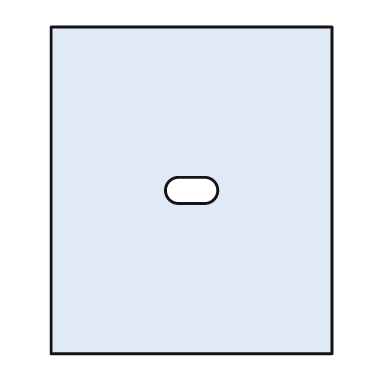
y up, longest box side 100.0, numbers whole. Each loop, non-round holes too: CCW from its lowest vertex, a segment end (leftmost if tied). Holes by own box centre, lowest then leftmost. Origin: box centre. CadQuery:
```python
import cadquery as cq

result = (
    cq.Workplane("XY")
    .moveTo(-43.0, -50.0)
    .lineTo(43.0, -50.0)
    .lineTo(43.0, 50.0)
    .lineTo(-43.0, 50.0)
    .close()
    .moveTo(-4.0, -4.0)
    .lineTo(4.0, -4.0)
    .threePointArc((8.0, 0.0), (4.0, 4.0))
    .lineTo(-4.0, 4.0)
    .threePointArc((-8.0, 0.0), (-4.0, -4.0))
    .close()
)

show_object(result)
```